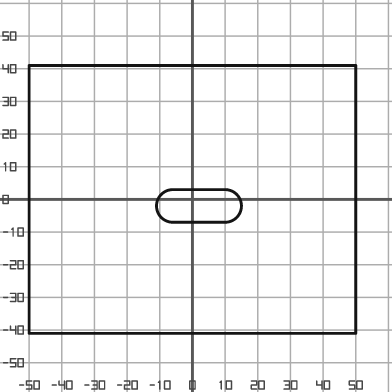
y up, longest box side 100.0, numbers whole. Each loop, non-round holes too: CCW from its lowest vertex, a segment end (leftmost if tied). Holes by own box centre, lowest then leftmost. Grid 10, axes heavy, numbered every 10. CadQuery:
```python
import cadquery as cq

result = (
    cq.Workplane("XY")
    .moveTo(-50.0, -41.0)
    .lineTo(50.0, -41.0)
    .lineTo(50.0, 41.0)
    .lineTo(-50.0, 41.0)
    .close()
    .moveTo(-6.0, -7.0)
    .lineTo(10.0, -7.0)
    .threePointArc((15.0, -2.0), (10.0, 3.0))
    .lineTo(-6.0, 3.0)
    .threePointArc((-11.0, -2.0), (-6.0, -7.0))
    .close()
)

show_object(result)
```